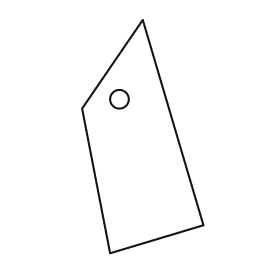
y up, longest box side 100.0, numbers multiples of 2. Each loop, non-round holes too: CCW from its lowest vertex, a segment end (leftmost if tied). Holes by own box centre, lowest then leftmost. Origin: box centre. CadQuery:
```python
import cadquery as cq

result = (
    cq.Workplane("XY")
    .moveTo(-14.0, -50.0)
    .lineTo(26.0, -38.0)
    .lineTo(0.0, 50.0)
    .lineTo(-26.0, 12.0)
    .close()
    .moveTo(-10.0, 16.0)
    .circle(4.0)
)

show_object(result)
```